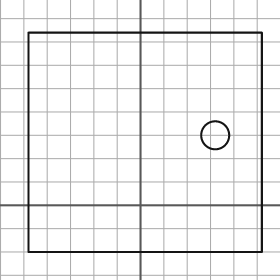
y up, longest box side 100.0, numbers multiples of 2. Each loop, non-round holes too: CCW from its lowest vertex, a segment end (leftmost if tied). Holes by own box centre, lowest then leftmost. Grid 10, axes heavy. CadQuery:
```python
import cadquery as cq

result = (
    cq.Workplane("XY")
    .moveTo(-48.0, -20.0)
    .lineTo(52.0, -20.0)
    .lineTo(52.0, 74.0)
    .lineTo(-48.0, 74.0)
    .close()
    .moveTo(32.0, 30.0)
    .circle(6.0)
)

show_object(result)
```